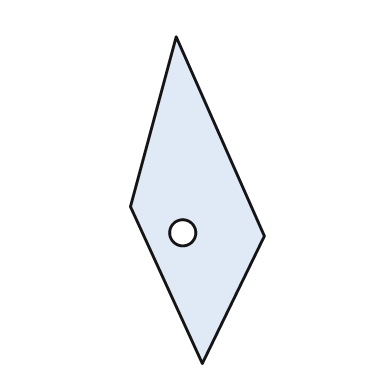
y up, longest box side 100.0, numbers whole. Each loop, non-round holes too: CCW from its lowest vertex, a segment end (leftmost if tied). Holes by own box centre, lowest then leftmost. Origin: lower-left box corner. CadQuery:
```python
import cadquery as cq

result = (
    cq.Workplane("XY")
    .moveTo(22.0, 0.0)
    .lineTo(41.0, 39.0)
    .lineTo(14.0, 100.0)
    .lineTo(0.0, 48.0)
    .close()
    .moveTo(16.0, 40.0)
    .circle(4.0)
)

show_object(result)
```